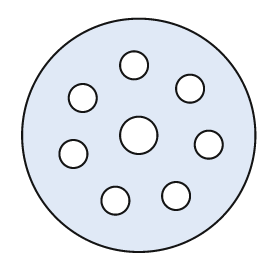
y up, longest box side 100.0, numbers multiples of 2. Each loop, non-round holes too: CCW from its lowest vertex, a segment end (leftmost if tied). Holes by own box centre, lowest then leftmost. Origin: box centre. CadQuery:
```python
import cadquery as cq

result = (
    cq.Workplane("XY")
    .moveTo(0.0, 0.0)
    .circle(50.0)
    .moveTo(-10.0, -28.0)
    .circle(6.0)
    .moveTo(16.0, -26.0)
    .circle(6.0)
    .moveTo(-28.0, -8.0)
    .circle(6.0)
    .moveTo(30.0, -4.0)
    .circle(6.0)
    .moveTo(0.0, 0.0)
    .circle(8.0)
    .moveTo(-24.0, 16.0)
    .circle(6.0)
    .moveTo(22.0, 20.0)
    .circle(6.0)
    .moveTo(-2.0, 30.0)
    .circle(6.0)
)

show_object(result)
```